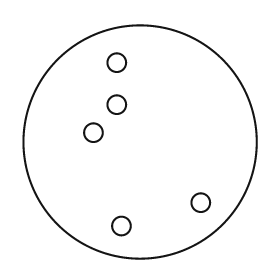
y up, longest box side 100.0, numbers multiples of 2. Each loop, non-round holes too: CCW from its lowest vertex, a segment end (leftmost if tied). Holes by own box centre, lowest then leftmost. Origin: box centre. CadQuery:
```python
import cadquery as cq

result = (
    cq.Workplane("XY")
    .moveTo(0.0, 0.0)
    .circle(50.0)
    .moveTo(-8.0, -36.0)
    .circle(4.0)
    .moveTo(26.0, -26.0)
    .circle(4.0)
    .moveTo(-20.0, 4.0)
    .circle(4.0)
    .moveTo(-10.0, 16.0)
    .circle(4.0)
    .moveTo(-10.0, 34.0)
    .circle(4.0)
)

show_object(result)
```